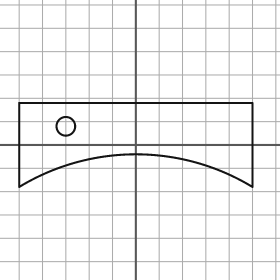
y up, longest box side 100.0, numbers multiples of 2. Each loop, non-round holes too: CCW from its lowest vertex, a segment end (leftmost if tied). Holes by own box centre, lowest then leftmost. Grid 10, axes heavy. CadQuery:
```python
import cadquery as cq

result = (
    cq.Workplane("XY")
    .moveTo(-50.0, -18.0)
    .threePointArc((0.0, -4.0), (50.0, -18.0))
    .lineTo(50.0, 18.0)
    .lineTo(-50.0, 18.0)
    .close()
    .moveTo(-30.0, 8.0)
    .circle(4.0)
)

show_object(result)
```